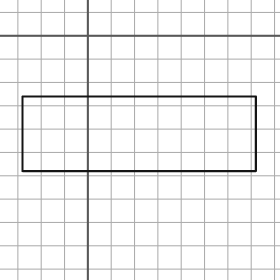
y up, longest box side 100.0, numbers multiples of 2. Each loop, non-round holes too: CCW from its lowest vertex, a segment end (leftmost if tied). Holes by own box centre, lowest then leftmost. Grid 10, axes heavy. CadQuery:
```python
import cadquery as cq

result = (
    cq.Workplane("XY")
    .moveTo(-28.0, -58.0)
    .lineTo(72.0, -58.0)
    .lineTo(72.0, -26.0)
    .lineTo(-28.0, -26.0)
    .close()
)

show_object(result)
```